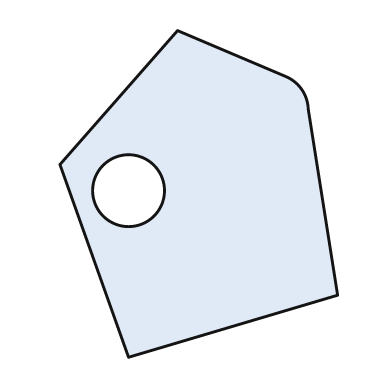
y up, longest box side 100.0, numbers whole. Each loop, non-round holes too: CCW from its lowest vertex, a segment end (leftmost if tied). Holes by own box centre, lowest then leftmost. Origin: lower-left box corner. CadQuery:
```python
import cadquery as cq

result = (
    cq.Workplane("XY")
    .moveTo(21.0, 0.0)
    .lineTo(85.0, 19.0)
    .lineTo(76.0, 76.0)
    .threePointArc((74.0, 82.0), (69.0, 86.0))
    .lineTo(36.0, 100.0)
    .lineTo(0.0, 59.0)
    .close()
    .moveTo(21.0, 51.0)
    .circle(11.0)
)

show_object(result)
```